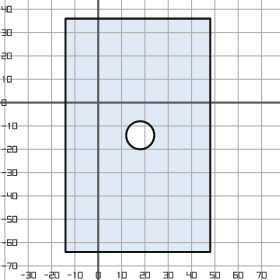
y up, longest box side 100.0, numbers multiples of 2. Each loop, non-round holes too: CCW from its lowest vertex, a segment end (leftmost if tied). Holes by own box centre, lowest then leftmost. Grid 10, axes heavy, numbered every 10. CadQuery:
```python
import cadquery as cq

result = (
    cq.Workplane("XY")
    .moveTo(-14.0, -64.0)
    .lineTo(48.0, -64.0)
    .lineTo(48.0, 36.0)
    .lineTo(-14.0, 36.0)
    .close()
    .moveTo(18.0, -14.0)
    .circle(6.0)
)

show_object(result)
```